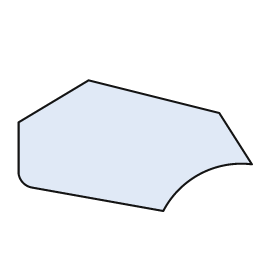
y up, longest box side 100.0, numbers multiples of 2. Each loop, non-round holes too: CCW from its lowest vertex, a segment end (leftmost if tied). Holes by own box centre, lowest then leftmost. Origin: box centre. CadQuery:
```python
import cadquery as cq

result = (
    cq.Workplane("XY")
    .moveTo(12.0, -28.0)
    .threePointArc((28.0, -12.0), (50.0, -8.0))
    .lineTo(36.0, 14.0)
    .lineTo(-20.0, 28.0)
    .lineTo(-50.0, 10.0)
    .lineTo(-50.0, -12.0)
    .threePointArc((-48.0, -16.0), (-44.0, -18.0))
    .close()
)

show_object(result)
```